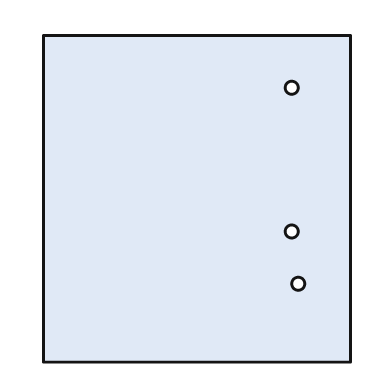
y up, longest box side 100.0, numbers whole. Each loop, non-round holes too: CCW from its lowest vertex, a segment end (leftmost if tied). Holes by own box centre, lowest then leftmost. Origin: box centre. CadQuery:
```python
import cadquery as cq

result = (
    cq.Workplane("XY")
    .moveTo(-47.0, -50.0)
    .lineTo(47.0, -50.0)
    .lineTo(47.0, 50.0)
    .lineTo(-47.0, 50.0)
    .close()
    .moveTo(31.0, -26.0)
    .circle(2.0)
    .moveTo(29.0, -10.0)
    .circle(2.0)
    .moveTo(29.0, 34.0)
    .circle(2.0)
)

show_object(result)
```